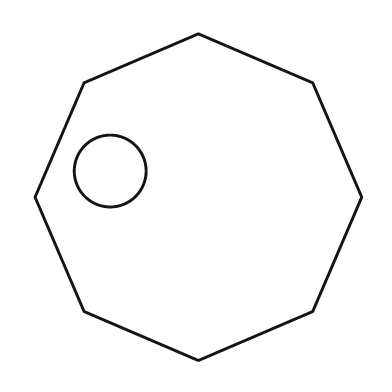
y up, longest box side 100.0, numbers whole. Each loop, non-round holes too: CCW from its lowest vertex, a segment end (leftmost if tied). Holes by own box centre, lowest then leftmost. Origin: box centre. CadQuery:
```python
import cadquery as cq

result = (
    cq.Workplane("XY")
    .moveTo(0.0, -50.0)
    .lineTo(35.0, -35.0)
    .lineTo(50.0, 0.0)
    .lineTo(35.0, 35.0)
    .lineTo(0.0, 50.0)
    .lineTo(-35.0, 35.0)
    .lineTo(-50.0, 0.0)
    .lineTo(-35.0, -35.0)
    .close()
    .moveTo(-27.0, 8.0)
    .circle(11.0)
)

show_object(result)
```